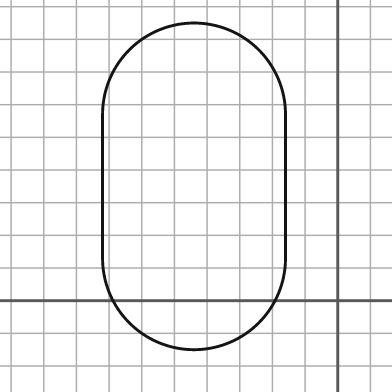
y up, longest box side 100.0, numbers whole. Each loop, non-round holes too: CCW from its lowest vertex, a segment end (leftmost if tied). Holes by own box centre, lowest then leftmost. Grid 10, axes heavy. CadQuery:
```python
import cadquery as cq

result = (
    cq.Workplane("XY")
    .moveTo(-72.0, 13.0)
    .threePointArc((-44.0, -15.0), (-16.0, 13.0))
    .lineTo(-16.0, 57.0)
    .threePointArc((-44.0, 85.0), (-72.0, 57.0))
    .close()
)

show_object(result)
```